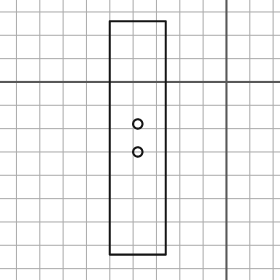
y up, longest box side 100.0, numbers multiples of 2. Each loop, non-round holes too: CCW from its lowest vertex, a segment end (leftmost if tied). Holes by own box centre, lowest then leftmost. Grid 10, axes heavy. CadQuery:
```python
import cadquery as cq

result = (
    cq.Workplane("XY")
    .moveTo(-50.0, -74.0)
    .lineTo(-26.0, -74.0)
    .lineTo(-26.0, 26.0)
    .lineTo(-50.0, 26.0)
    .close()
    .moveTo(-38.0, -30.0)
    .circle(2.0)
    .moveTo(-38.0, -18.0)
    .circle(2.0)
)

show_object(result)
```